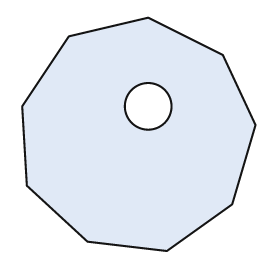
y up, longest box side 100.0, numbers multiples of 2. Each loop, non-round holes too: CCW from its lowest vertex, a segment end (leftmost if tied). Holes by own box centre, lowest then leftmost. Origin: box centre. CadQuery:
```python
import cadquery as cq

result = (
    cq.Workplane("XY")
    .moveTo(12.0, -50.0)
    .lineTo(40.0, -30.0)
    .lineTo(50.0, 4.0)
    .lineTo(36.0, 34.0)
    .lineTo(4.0, 50.0)
    .lineTo(-30.0, 42.0)
    .lineTo(-50.0, 12.0)
    .lineTo(-48.0, -22.0)
    .lineTo(-22.0, -46.0)
    .close()
    .moveTo(4.0, 12.0)
    .circle(10.0)
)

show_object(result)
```